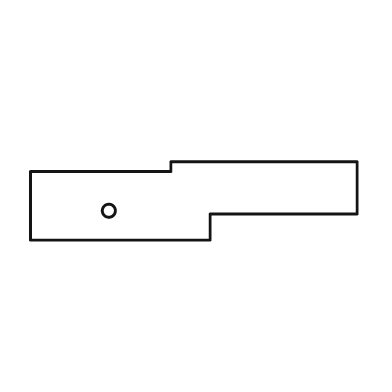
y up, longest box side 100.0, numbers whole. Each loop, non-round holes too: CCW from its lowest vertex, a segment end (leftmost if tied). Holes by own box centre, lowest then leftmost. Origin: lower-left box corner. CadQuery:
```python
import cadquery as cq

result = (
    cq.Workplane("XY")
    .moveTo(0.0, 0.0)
    .lineTo(55.0, 0.0)
    .lineTo(55.0, 8.0)
    .lineTo(100.0, 8.0)
    .lineTo(100.0, 24.0)
    .lineTo(43.0, 24.0)
    .lineTo(43.0, 21.0)
    .lineTo(0.0, 21.0)
    .close()
    .moveTo(24.0, 9.0)
    .circle(2.0)
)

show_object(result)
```